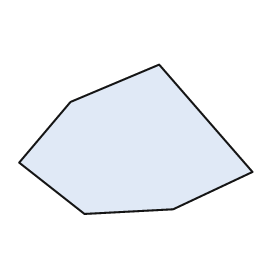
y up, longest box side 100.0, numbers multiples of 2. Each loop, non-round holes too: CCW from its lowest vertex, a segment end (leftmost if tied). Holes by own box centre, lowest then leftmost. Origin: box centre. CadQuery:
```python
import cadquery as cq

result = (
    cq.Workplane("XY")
    .moveTo(-22.0, -32.0)
    .lineTo(16.0, -30.0)
    .lineTo(50.0, -14.0)
    .lineTo(10.0, 32.0)
    .lineTo(-28.0, 16.0)
    .lineTo(-50.0, -10.0)
    .close()
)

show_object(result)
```